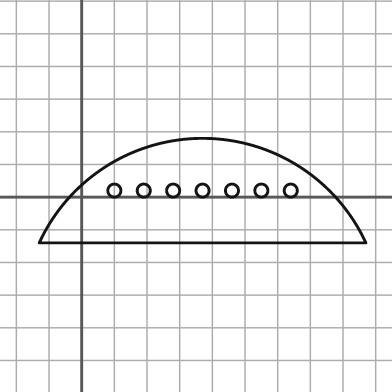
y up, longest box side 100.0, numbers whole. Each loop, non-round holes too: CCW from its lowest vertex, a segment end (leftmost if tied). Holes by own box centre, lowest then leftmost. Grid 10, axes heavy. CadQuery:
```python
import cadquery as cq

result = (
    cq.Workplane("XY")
    .moveTo(-13.0, -14.0)
    .lineTo(87.0, -14.0)
    .threePointArc((37.0, 18.0), (-13.0, -14.0))
    .close()
    .moveTo(10.0, 2.0)
    .circle(2.0)
    .moveTo(19.0, 2.0)
    .circle(2.0)
    .moveTo(28.0, 2.0)
    .circle(2.0)
    .moveTo(37.0, 2.0)
    .circle(2.0)
    .moveTo(46.0, 2.0)
    .circle(2.0)
    .moveTo(55.0, 2.0)
    .circle(2.0)
    .moveTo(64.0, 2.0)
    .circle(2.0)
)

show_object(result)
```